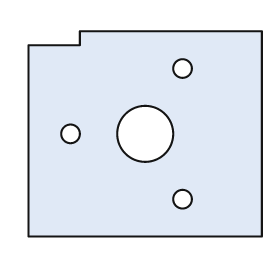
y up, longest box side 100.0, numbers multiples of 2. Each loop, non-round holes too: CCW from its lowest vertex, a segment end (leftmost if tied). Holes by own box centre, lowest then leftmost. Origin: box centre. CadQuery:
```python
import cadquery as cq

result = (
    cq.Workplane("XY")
    .moveTo(-50.0, -44.0)
    .lineTo(50.0, -44.0)
    .lineTo(50.0, 44.0)
    .lineTo(-28.0, 44.0)
    .lineTo(-28.0, 38.0)
    .lineTo(-50.0, 38.0)
    .close()
    .moveTo(16.0, -28.0)
    .circle(4.0)
    .moveTo(-32.0, 0.0)
    .circle(4.0)
    .moveTo(0.0, 0.0)
    .circle(12.0)
    .moveTo(16.0, 28.0)
    .circle(4.0)
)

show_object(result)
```